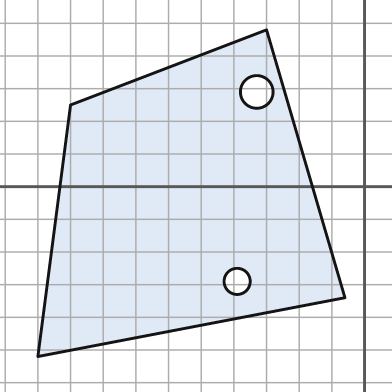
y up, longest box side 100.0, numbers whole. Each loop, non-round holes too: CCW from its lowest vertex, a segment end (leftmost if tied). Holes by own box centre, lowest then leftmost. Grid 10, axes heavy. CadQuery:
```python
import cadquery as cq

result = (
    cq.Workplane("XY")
    .moveTo(-100.0, -52.0)
    .lineTo(-6.0, -34.0)
    .lineTo(-30.0, 48.0)
    .lineTo(-90.0, 25.0)
    .close()
    .moveTo(-39.0, -29.0)
    .circle(4.0)
    .moveTo(-33.0, 29.0)
    .circle(5.0)
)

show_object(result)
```